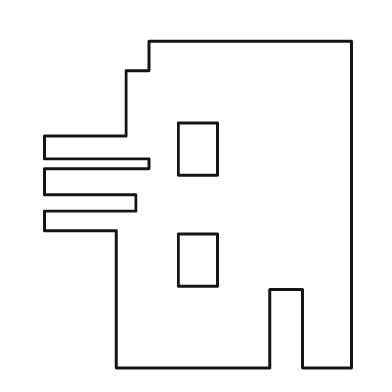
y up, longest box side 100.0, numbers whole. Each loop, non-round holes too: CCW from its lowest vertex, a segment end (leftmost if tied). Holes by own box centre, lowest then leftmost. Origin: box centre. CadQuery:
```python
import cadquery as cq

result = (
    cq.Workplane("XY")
    .moveTo(-25.0, -50.0)
    .lineTo(22.0, -50.0)
    .lineTo(22.0, -26.0)
    .lineTo(32.0, -26.0)
    .lineTo(32.0, -50.0)
    .lineTo(47.0, -50.0)
    .lineTo(47.0, 50.0)
    .lineTo(-15.0, 50.0)
    .lineTo(-15.0, 41.0)
    .lineTo(-22.0, 41.0)
    .lineTo(-22.0, 21.0)
    .lineTo(-47.0, 21.0)
    .lineTo(-47.0, 14.0)
    .lineTo(-15.0, 14.0)
    .lineTo(-15.0, 11.0)
    .lineTo(-47.0, 11.0)
    .lineTo(-47.0, 3.0)
    .lineTo(-19.0, 3.0)
    .lineTo(-19.0, -2.0)
    .lineTo(-47.0, -2.0)
    .lineTo(-47.0, -8.0)
    .lineTo(-25.0, -8.0)
    .close()
    .moveTo(-6.0, -25.0)
    .lineTo(6.0, -25.0)
    .lineTo(6.0, -9.0)
    .lineTo(-6.0, -9.0)
    .close()
    .moveTo(-6.0, 9.0)
    .lineTo(6.0, 9.0)
    .lineTo(6.0, 25.0)
    .lineTo(-6.0, 25.0)
    .close()
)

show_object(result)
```